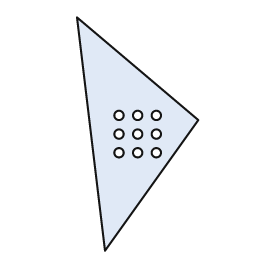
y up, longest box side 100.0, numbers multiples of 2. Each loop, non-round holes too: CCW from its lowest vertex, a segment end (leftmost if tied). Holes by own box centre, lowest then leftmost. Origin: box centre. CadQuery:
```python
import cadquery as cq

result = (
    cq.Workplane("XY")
    .moveTo(-14.0, -50.0)
    .lineTo(26.0, 6.0)
    .lineTo(-26.0, 50.0)
    .close()
    .moveTo(-8.0, -8.0)
    .circle(2.0)
    .moveTo(0.0, -8.0)
    .circle(2.0)
    .moveTo(8.0, -8.0)
    .circle(2.0)
    .moveTo(-8.0, 0.0)
    .circle(2.0)
    .moveTo(0.0, 0.0)
    .circle(2.0)
    .moveTo(8.0, 0.0)
    .circle(2.0)
    .moveTo(-8.0, 8.0)
    .circle(2.0)
    .moveTo(0.0, 8.0)
    .circle(2.0)
    .moveTo(8.0, 8.0)
    .circle(2.0)
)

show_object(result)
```